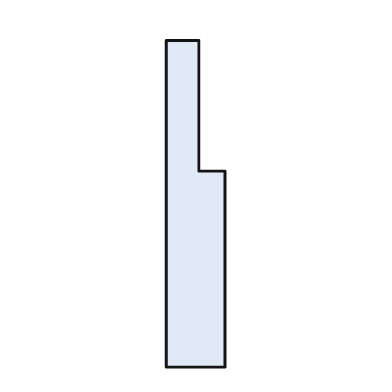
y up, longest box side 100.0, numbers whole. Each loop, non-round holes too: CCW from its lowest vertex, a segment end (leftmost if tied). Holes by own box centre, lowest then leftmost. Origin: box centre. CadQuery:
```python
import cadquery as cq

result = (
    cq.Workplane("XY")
    .moveTo(-9.0, -50.0)
    .lineTo(9.0, -50.0)
    .lineTo(9.0, 10.0)
    .lineTo(1.0, 10.0)
    .lineTo(1.0, 50.0)
    .lineTo(-9.0, 50.0)
    .close()
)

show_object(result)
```